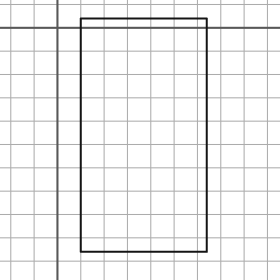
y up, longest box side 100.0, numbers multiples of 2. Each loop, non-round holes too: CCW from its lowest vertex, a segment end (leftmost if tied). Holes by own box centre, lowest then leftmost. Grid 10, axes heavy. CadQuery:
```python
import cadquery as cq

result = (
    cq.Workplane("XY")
    .moveTo(10.0, -96.0)
    .lineTo(64.0, -96.0)
    .lineTo(64.0, 4.0)
    .lineTo(10.0, 4.0)
    .close()
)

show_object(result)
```